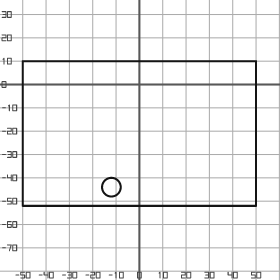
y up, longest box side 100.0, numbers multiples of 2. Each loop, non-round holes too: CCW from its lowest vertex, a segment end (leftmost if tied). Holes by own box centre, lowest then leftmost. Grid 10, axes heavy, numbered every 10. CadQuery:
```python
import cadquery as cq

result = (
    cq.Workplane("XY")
    .moveTo(-50.0, -52.0)
    .lineTo(50.0, -52.0)
    .lineTo(50.0, 10.0)
    .lineTo(-50.0, 10.0)
    .close()
    .moveTo(-12.0, -44.0)
    .circle(4.0)
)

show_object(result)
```